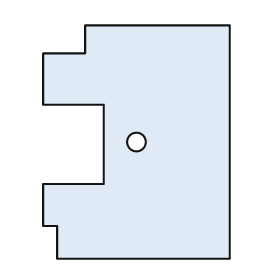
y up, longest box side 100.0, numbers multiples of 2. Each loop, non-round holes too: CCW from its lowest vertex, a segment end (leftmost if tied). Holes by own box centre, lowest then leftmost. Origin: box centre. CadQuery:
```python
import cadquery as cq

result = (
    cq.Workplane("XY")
    .moveTo(-34.0, -50.0)
    .lineTo(40.0, -50.0)
    .lineTo(40.0, 50.0)
    .lineTo(-22.0, 50.0)
    .lineTo(-22.0, 38.0)
    .lineTo(-40.0, 38.0)
    .lineTo(-40.0, 16.0)
    .lineTo(-14.0, 16.0)
    .lineTo(-14.0, -18.0)
    .lineTo(-40.0, -18.0)
    .lineTo(-40.0, -36.0)
    .lineTo(-34.0, -36.0)
    .close()
    .moveTo(0.0, 0.0)
    .circle(4.0)
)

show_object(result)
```